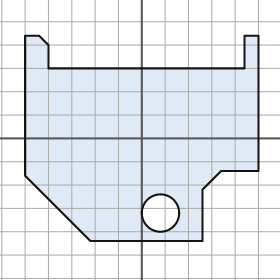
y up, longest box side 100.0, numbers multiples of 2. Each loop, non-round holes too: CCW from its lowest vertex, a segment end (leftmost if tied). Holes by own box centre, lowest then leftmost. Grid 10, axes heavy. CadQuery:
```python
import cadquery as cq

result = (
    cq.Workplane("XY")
    .moveTo(-22.0, -44.0)
    .lineTo(26.0, -44.0)
    .lineTo(26.0, -22.0)
    .lineTo(34.0, -14.0)
    .lineTo(50.0, -14.0)
    .lineTo(50.0, 44.0)
    .lineTo(44.0, 44.0)
    .lineTo(44.0, 30.0)
    .lineTo(-40.0, 30.0)
    .lineTo(-40.0, 40.0)
    .lineTo(-44.0, 44.0)
    .lineTo(-50.0, 44.0)
    .lineTo(-50.0, -16.0)
    .close()
    .moveTo(8.0, -32.0)
    .circle(8.0)
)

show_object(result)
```